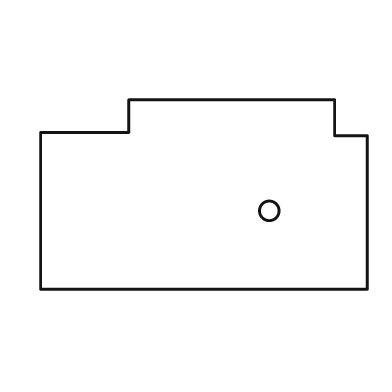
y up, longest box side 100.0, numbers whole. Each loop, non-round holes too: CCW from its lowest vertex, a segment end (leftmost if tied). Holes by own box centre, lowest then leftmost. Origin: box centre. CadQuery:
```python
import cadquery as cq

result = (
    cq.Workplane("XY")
    .moveTo(-50.0, -29.0)
    .lineTo(50.0, -29.0)
    .lineTo(50.0, 18.0)
    .lineTo(40.0, 18.0)
    .lineTo(40.0, 29.0)
    .lineTo(-23.0, 29.0)
    .lineTo(-23.0, 19.0)
    .lineTo(-50.0, 19.0)
    .close()
    .moveTo(20.0, -5.0)
    .circle(3.0)
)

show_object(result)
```